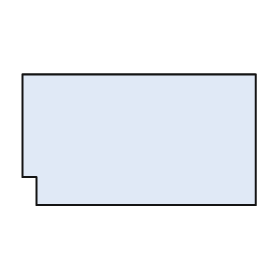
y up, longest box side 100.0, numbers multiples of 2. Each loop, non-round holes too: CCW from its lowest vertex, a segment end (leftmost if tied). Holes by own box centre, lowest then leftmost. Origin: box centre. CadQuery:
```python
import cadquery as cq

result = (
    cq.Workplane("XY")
    .moveTo(-44.0, -28.0)
    .lineTo(50.0, -28.0)
    .lineTo(50.0, 28.0)
    .lineTo(-50.0, 28.0)
    .lineTo(-50.0, -16.0)
    .lineTo(-44.0, -16.0)
    .close()
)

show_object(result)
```